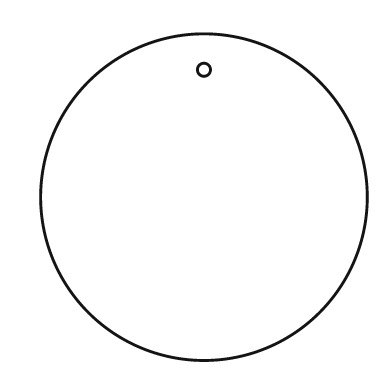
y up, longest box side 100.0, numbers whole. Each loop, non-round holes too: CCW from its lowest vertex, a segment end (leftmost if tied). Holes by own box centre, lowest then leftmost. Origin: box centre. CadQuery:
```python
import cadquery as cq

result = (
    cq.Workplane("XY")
    .moveTo(0.0, 0.0)
    .circle(50.0)
    .moveTo(0.0, 39.0)
    .circle(2.0)
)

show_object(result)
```